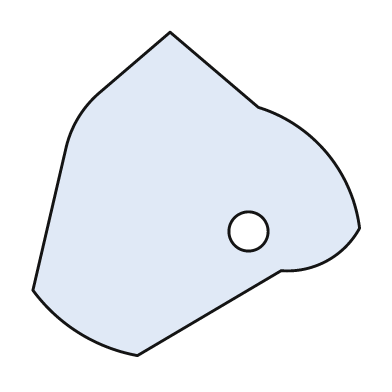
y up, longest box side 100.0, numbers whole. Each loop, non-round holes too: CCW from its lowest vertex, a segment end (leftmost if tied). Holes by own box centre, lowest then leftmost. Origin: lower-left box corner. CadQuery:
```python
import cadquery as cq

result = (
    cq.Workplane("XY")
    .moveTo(32.0, 0.0)
    .lineTo(76.0, 26.0)
    .threePointArc((90.0, 29.0), (100.0, 39.0))
    .threePointArc((90.0, 62.0), (69.0, 76.0))
    .lineTo(42.0, 99.0)
    .lineTo(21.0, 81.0)
    .threePointArc((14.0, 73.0), (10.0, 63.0))
    .lineTo(0.0, 20.0)
    .threePointArc((14.0, 7.0), (32.0, 0.0))
    .close()
    .moveTo(66.0, 38.0)
    .circle(6.0)
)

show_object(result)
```